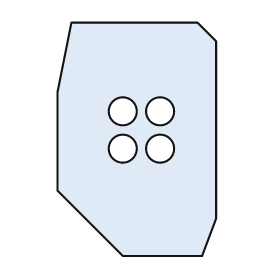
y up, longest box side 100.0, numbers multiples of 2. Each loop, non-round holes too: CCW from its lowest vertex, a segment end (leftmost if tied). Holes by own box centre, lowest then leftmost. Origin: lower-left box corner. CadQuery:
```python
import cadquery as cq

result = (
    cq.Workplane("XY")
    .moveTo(28.0, 0.0)
    .lineTo(62.0, 0.0)
    .lineTo(68.0, 16.0)
    .lineTo(68.0, 92.0)
    .lineTo(60.0, 100.0)
    .lineTo(6.0, 100.0)
    .lineTo(0.0, 70.0)
    .lineTo(0.0, 28.0)
    .close()
    .moveTo(28.0, 46.0)
    .circle(6.0)
    .moveTo(44.0, 46.0)
    .circle(6.0)
    .moveTo(28.0, 62.0)
    .circle(6.0)
    .moveTo(44.0, 62.0)
    .circle(6.0)
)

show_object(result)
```